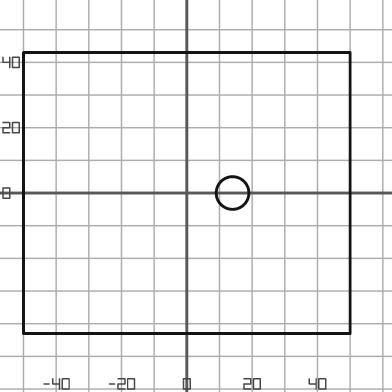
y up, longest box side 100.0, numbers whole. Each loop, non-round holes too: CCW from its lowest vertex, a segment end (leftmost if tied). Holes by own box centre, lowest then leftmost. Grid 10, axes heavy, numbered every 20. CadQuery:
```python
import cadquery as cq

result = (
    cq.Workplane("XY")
    .moveTo(-50.0, -43.0)
    .lineTo(50.0, -43.0)
    .lineTo(50.0, 43.0)
    .lineTo(-50.0, 43.0)
    .close()
    .moveTo(14.0, 0.0)
    .circle(5.0)
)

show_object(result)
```